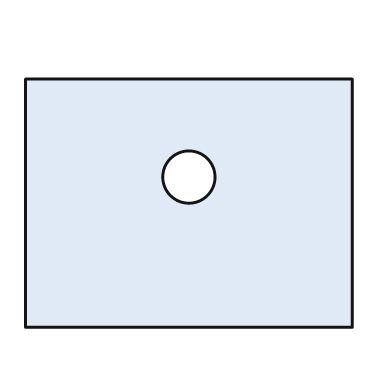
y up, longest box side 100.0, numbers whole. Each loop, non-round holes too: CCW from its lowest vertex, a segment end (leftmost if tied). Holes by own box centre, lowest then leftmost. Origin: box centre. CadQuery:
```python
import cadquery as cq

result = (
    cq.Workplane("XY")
    .moveTo(-50.0, -38.0)
    .lineTo(50.0, -38.0)
    .lineTo(50.0, 38.0)
    .lineTo(-50.0, 38.0)
    .close()
    .moveTo(0.0, 8.0)
    .circle(8.0)
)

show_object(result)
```